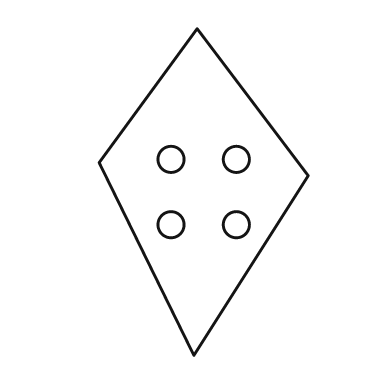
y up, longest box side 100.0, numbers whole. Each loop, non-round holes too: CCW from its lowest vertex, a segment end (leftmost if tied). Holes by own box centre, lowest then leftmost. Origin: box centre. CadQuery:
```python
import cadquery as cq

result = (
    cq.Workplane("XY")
    .moveTo(-3.0, -50.0)
    .lineTo(32.0, 5.0)
    .lineTo(-2.0, 50.0)
    .lineTo(-32.0, 9.0)
    .close()
    .moveTo(-10.0, -10.0)
    .circle(4.0)
    .moveTo(10.0, -10.0)
    .circle(4.0)
    .moveTo(-10.0, 10.0)
    .circle(4.0)
    .moveTo(10.0, 10.0)
    .circle(4.0)
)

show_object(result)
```